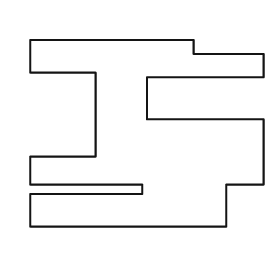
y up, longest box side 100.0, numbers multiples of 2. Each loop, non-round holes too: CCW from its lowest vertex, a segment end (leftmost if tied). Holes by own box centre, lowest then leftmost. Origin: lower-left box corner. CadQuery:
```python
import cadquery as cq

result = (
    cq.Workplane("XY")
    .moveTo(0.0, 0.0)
    .lineTo(84.0, 0.0)
    .lineTo(84.0, 18.0)
    .lineTo(100.0, 18.0)
    .lineTo(100.0, 46.0)
    .lineTo(50.0, 46.0)
    .lineTo(50.0, 64.0)
    .lineTo(100.0, 64.0)
    .lineTo(100.0, 74.0)
    .lineTo(70.0, 74.0)
    .lineTo(70.0, 80.0)
    .lineTo(0.0, 80.0)
    .lineTo(0.0, 66.0)
    .lineTo(28.0, 66.0)
    .lineTo(28.0, 30.0)
    .lineTo(0.0, 30.0)
    .lineTo(0.0, 18.0)
    .lineTo(48.0, 18.0)
    .lineTo(48.0, 14.0)
    .lineTo(0.0, 14.0)
    .close()
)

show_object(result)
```